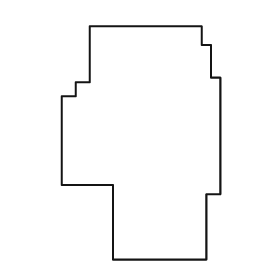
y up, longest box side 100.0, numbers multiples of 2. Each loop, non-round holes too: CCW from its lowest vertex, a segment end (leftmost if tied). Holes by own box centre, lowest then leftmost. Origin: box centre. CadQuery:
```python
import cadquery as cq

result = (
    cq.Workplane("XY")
    .moveTo(-12.0, -50.0)
    .lineTo(28.0, -50.0)
    .lineTo(28.0, -22.0)
    .lineTo(34.0, -22.0)
    .lineTo(34.0, 28.0)
    .lineTo(30.0, 28.0)
    .lineTo(30.0, 42.0)
    .lineTo(26.0, 42.0)
    .lineTo(26.0, 50.0)
    .lineTo(-22.0, 50.0)
    .lineTo(-22.0, 26.0)
    .lineTo(-28.0, 26.0)
    .lineTo(-28.0, 20.0)
    .lineTo(-34.0, 20.0)
    .lineTo(-34.0, -18.0)
    .lineTo(-12.0, -18.0)
    .close()
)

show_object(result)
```